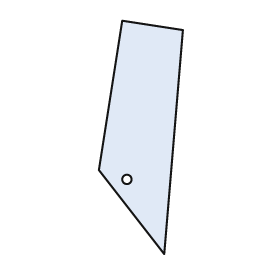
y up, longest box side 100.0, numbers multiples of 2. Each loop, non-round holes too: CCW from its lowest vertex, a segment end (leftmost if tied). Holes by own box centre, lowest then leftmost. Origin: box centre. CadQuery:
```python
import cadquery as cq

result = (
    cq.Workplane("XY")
    .moveTo(10.0, -50.0)
    .lineTo(18.0, 46.0)
    .lineTo(-8.0, 50.0)
    .lineTo(-18.0, -14.0)
    .close()
    .moveTo(-6.0, -18.0)
    .circle(2.0)
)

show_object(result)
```